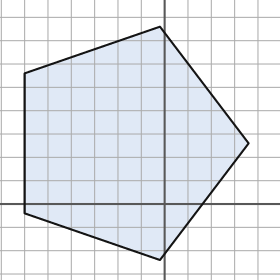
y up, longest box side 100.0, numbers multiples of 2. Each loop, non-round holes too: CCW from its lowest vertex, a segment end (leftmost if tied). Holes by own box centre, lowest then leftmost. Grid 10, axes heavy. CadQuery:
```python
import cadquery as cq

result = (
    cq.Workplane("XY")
    .moveTo(-2.0, -24.0)
    .lineTo(36.0, 26.0)
    .lineTo(-2.0, 76.0)
    .lineTo(-60.0, 56.0)
    .lineTo(-60.0, -4.0)
    .close()
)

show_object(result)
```